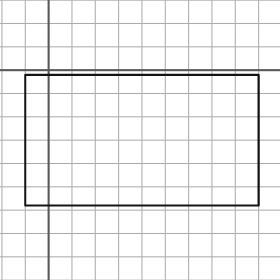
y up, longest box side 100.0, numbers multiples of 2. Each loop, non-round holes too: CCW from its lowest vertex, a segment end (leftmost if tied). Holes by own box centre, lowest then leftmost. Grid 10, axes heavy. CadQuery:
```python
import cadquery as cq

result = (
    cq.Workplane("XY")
    .moveTo(-10.0, -58.0)
    .lineTo(90.0, -58.0)
    .lineTo(90.0, -2.0)
    .lineTo(-10.0, -2.0)
    .close()
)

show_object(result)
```